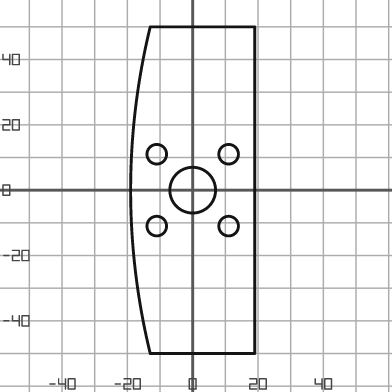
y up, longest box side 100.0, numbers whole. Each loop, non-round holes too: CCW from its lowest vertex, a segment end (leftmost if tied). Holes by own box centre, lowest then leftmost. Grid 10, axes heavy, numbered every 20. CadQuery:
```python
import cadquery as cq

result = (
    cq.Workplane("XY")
    .moveTo(-13.0, -50.0)
    .lineTo(19.0, -50.0)
    .lineTo(19.0, 50.0)
    .lineTo(-13.0, 50.0)
    .threePointArc((-19.0, 0.0), (-13.0, -50.0))
    .close()
    .moveTo(-11.0, -11.0)
    .circle(3.0)
    .moveTo(11.0, -11.0)
    .circle(3.0)
    .moveTo(0.0, 0.0)
    .circle(7.0)
    .moveTo(-11.0, 11.0)
    .circle(3.0)
    .moveTo(11.0, 11.0)
    .circle(3.0)
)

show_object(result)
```